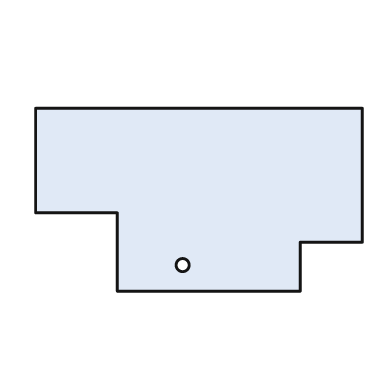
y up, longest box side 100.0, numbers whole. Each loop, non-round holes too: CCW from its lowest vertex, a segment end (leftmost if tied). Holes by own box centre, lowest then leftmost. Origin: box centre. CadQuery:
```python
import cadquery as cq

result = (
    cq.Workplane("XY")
    .moveTo(-25.0, -28.0)
    .lineTo(31.0, -28.0)
    .lineTo(31.0, -13.0)
    .lineTo(50.0, -13.0)
    .lineTo(50.0, 28.0)
    .lineTo(-50.0, 28.0)
    .lineTo(-50.0, -4.0)
    .lineTo(-25.0, -4.0)
    .close()
    .moveTo(-5.0, -20.0)
    .circle(2.0)
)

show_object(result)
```